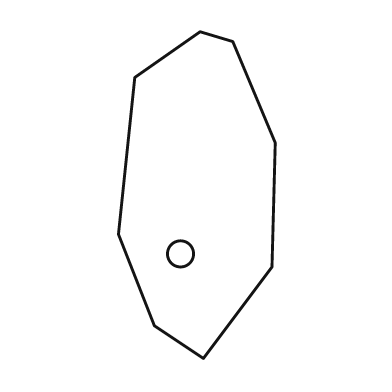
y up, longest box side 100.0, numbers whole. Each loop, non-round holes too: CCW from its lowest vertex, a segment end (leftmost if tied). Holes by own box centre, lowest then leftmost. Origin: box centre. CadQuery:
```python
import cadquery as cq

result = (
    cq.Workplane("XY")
    .moveTo(2.0, -50.0)
    .lineTo(23.0, -22.0)
    .lineTo(24.0, 16.0)
    .lineTo(11.0, 47.0)
    .lineTo(1.0, 50.0)
    .lineTo(-19.0, 36.0)
    .lineTo(-24.0, -12.0)
    .lineTo(-13.0, -40.0)
    .close()
    .moveTo(-5.0, -18.0)
    .circle(4.0)
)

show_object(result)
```